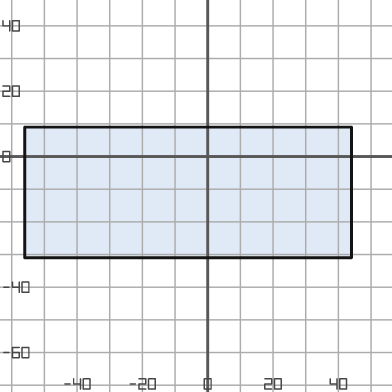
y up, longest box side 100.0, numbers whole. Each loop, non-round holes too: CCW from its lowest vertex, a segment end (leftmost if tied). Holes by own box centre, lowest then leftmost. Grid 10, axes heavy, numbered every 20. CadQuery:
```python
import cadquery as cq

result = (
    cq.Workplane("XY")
    .moveTo(-56.0, -31.0)
    .lineTo(44.0, -31.0)
    .lineTo(44.0, 9.0)
    .lineTo(-56.0, 9.0)
    .close()
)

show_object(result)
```